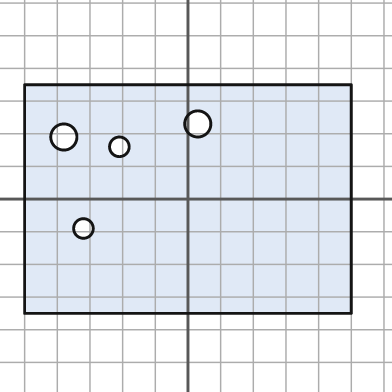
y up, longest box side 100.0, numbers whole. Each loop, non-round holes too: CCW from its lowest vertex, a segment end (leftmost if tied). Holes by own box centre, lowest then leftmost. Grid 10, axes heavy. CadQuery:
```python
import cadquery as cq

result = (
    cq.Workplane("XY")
    .moveTo(-50.0, -35.0)
    .lineTo(50.0, -35.0)
    .lineTo(50.0, 35.0)
    .lineTo(-50.0, 35.0)
    .close()
    .moveTo(-32.0, -9.0)
    .circle(3.0)
    .moveTo(-21.0, 16.0)
    .circle(3.0)
    .moveTo(-38.0, 19.0)
    .circle(4.0)
    .moveTo(3.0, 23.0)
    .circle(4.0)
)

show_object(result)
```